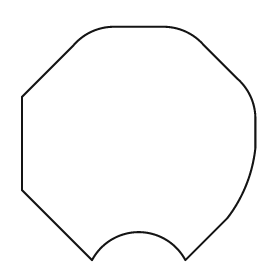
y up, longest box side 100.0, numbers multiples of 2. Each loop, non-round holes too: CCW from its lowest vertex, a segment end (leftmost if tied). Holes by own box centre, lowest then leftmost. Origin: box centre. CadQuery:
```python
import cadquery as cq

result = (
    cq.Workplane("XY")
    .moveTo(-20.0, -50.0)
    .threePointArc((0.0, -38.0), (20.0, -50.0))
    .lineTo(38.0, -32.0)
    .threePointArc((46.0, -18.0), (50.0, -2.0))
    .lineTo(50.0, 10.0)
    .threePointArc((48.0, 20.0), (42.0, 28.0))
    .lineTo(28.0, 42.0)
    .threePointArc((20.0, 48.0), (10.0, 50.0))
    .lineTo(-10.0, 50.0)
    .threePointArc((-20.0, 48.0), (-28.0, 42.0))
    .lineTo(-50.0, 20.0)
    .lineTo(-50.0, -20.0)
    .close()
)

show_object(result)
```